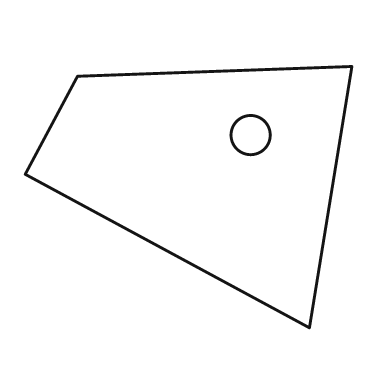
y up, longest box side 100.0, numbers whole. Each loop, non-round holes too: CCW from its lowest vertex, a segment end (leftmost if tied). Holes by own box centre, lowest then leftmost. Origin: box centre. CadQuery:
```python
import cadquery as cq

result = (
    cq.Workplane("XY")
    .moveTo(37.0, -40.0)
    .lineTo(50.0, 40.0)
    .lineTo(-34.0, 37.0)
    .lineTo(-50.0, 7.0)
    .close()
    .moveTo(19.0, 19.0)
    .circle(6.0)
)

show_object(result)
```